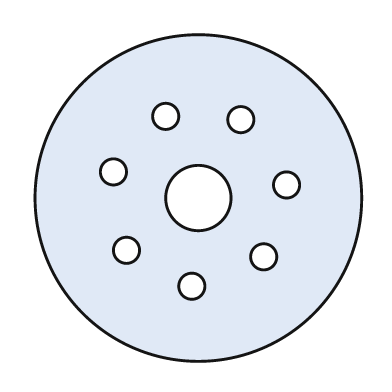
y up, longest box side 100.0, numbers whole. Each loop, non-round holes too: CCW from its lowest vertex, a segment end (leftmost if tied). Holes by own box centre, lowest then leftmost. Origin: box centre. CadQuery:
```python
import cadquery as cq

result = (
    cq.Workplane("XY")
    .moveTo(0.0, 0.0)
    .circle(50.0)
    .moveTo(-2.0, -27.0)
    .circle(4.0)
    .moveTo(20.0, -18.0)
    .circle(4.0)
    .moveTo(-22.0, -16.0)
    .circle(4.0)
    .moveTo(0.0, 0.0)
    .circle(10.0)
    .moveTo(27.0, 4.0)
    .circle(4.0)
    .moveTo(-26.0, 8.0)
    .circle(4.0)
    .moveTo(13.0, 24.0)
    .circle(4.0)
    .moveTo(-10.0, 25.0)
    .circle(4.0)
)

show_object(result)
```